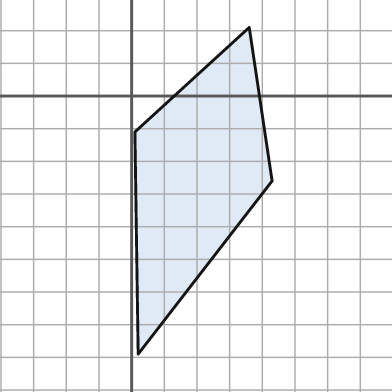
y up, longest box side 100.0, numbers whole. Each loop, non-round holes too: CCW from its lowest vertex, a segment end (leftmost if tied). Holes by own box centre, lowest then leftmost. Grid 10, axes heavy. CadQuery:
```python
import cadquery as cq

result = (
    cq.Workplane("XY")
    .moveTo(2.0, -79.0)
    .lineTo(43.0, -26.0)
    .lineTo(36.0, 21.0)
    .lineTo(1.0, -11.0)
    .close()
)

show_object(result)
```